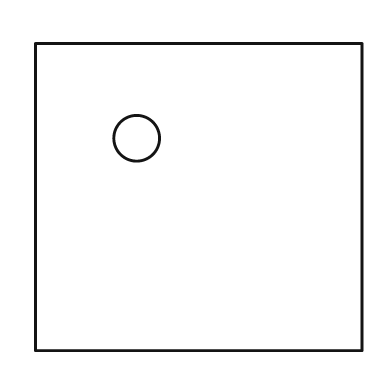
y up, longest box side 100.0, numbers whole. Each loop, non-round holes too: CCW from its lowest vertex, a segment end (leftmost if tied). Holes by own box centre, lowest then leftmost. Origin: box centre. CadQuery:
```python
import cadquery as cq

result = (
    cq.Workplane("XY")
    .moveTo(-50.0, -47.0)
    .lineTo(50.0, -47.0)
    .lineTo(50.0, 47.0)
    .lineTo(-50.0, 47.0)
    .close()
    .moveTo(-19.0, 18.0)
    .circle(7.0)
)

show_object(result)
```